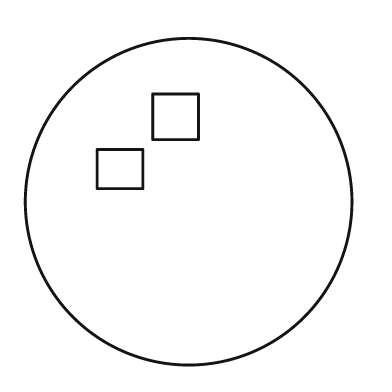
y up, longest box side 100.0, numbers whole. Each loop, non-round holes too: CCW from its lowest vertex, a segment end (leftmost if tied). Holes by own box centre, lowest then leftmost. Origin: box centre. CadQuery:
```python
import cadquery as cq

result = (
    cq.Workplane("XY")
    .moveTo(0.0, 0.0)
    .circle(50.0)
    .moveTo(-28.0, 4.0)
    .lineTo(-14.0, 4.0)
    .lineTo(-14.0, 16.0)
    .lineTo(-28.0, 16.0)
    .close()
    .moveTo(-11.0, 19.0)
    .lineTo(3.0, 19.0)
    .lineTo(3.0, 33.0)
    .lineTo(-11.0, 33.0)
    .close()
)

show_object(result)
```